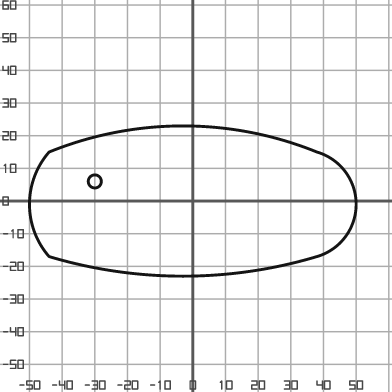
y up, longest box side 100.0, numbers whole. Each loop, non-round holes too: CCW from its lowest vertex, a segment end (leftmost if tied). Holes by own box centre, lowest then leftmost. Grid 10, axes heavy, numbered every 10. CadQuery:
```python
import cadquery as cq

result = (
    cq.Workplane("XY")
    .moveTo(-44.0, -17.0)
    .threePointArc((-3.0, -23.0), (38.0, -17.0))
    .threePointArc((50.0, -1.0), (38.0, 15.0))
    .threePointArc((-3.0, 23.0), (-44.0, 15.0))
    .threePointArc((-50.0, -1.0), (-44.0, -17.0))
    .close()
    .moveTo(-30.0, 6.0)
    .circle(2.0)
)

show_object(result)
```